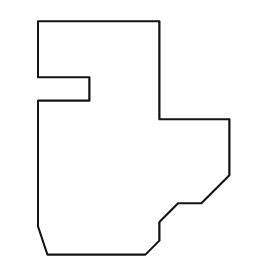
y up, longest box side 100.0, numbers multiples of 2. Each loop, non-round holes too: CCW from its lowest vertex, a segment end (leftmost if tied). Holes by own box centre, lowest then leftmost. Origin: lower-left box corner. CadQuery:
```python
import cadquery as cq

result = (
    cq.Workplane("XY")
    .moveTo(4.0, 0.0)
    .lineTo(46.0, 0.0)
    .lineTo(52.0, 6.0)
    .lineTo(52.0, 14.0)
    .lineTo(60.0, 22.0)
    .lineTo(70.0, 22.0)
    .lineTo(82.0, 34.0)
    .lineTo(82.0, 58.0)
    .lineTo(52.0, 58.0)
    .lineTo(52.0, 100.0)
    .lineTo(0.0, 100.0)
    .lineTo(0.0, 76.0)
    .lineTo(22.0, 76.0)
    .lineTo(22.0, 66.0)
    .lineTo(0.0, 66.0)
    .lineTo(0.0, 12.0)
    .close()
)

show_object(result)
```